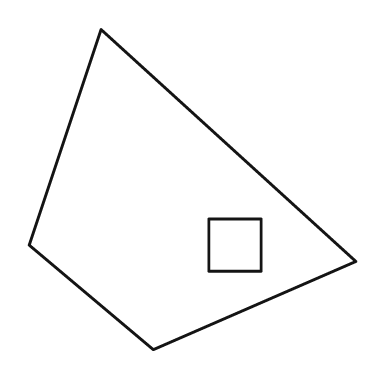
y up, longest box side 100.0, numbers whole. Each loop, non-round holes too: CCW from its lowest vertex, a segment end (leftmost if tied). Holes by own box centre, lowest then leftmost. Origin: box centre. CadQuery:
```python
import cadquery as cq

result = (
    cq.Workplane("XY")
    .moveTo(-12.0, -49.0)
    .lineTo(50.0, -22.0)
    .lineTo(-28.0, 49.0)
    .lineTo(-50.0, -17.0)
    .close()
    .moveTo(5.0, -25.0)
    .lineTo(21.0, -25.0)
    .lineTo(21.0, -9.0)
    .lineTo(5.0, -9.0)
    .close()
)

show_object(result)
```